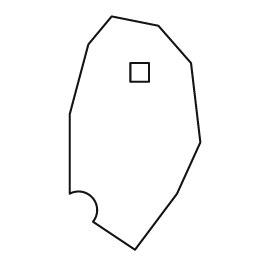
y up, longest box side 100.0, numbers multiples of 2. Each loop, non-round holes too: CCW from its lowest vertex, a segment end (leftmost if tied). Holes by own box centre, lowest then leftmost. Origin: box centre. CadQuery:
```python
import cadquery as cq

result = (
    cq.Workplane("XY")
    .moveTo(0.0, -50.0)
    .lineTo(18.0, -26.0)
    .lineTo(28.0, -4.0)
    .lineTo(24.0, 30.0)
    .lineTo(10.0, 46.0)
    .lineTo(-10.0, 50.0)
    .lineTo(-20.0, 38.0)
    .lineTo(-28.0, 8.0)
    .lineTo(-28.0, -26.0)
    .threePointArc((-18.0, -28.0), (-18.0, -38.0))
    .close()
    .moveTo(-2.0, 22.0)
    .lineTo(6.0, 22.0)
    .lineTo(6.0, 30.0)
    .lineTo(-2.0, 30.0)
    .close()
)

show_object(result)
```